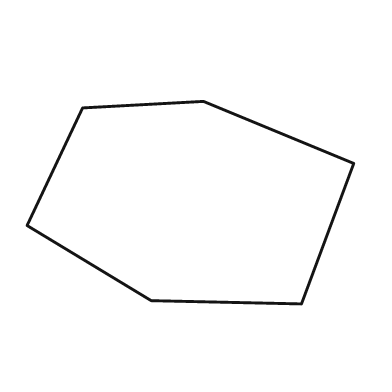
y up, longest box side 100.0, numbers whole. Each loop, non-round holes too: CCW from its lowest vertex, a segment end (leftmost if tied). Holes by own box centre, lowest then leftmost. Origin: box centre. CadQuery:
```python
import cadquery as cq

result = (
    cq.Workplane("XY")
    .moveTo(34.0, -31.0)
    .lineTo(50.0, 12.0)
    .lineTo(4.0, 31.0)
    .lineTo(-33.0, 29.0)
    .lineTo(-50.0, -7.0)
    .lineTo(-12.0, -30.0)
    .close()
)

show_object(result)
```